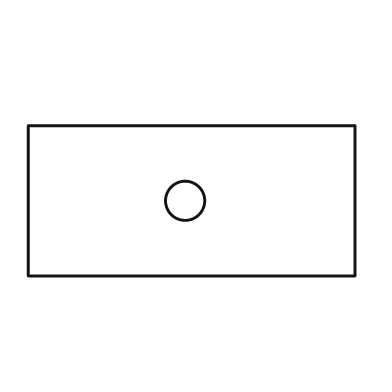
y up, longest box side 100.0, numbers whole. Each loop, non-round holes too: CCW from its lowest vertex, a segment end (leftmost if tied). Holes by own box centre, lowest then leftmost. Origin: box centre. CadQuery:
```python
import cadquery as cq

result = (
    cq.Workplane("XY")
    .moveTo(-50.0, -23.0)
    .lineTo(50.0, -23.0)
    .lineTo(50.0, 23.0)
    .lineTo(-50.0, 23.0)
    .close()
    .moveTo(-2.0, 0.0)
    .circle(6.0)
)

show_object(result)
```